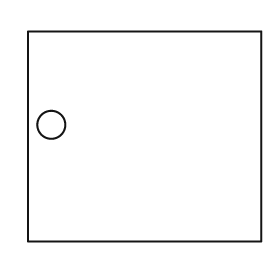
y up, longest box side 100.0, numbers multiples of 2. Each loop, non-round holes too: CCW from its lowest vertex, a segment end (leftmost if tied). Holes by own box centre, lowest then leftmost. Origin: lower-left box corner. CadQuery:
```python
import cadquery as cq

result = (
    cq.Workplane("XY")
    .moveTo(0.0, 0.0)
    .lineTo(100.0, 0.0)
    .lineTo(100.0, 90.0)
    .lineTo(0.0, 90.0)
    .close()
    .moveTo(10.0, 50.0)
    .circle(6.0)
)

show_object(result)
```